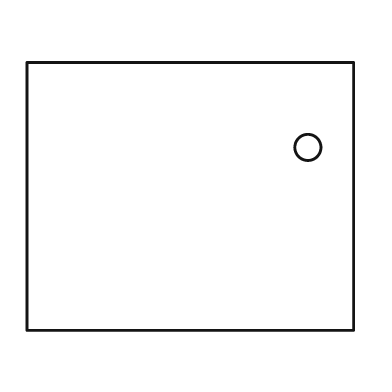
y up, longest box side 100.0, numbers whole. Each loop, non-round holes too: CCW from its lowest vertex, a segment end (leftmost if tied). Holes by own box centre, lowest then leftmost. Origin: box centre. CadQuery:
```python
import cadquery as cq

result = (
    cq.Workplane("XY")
    .moveTo(-50.0, -41.0)
    .lineTo(50.0, -41.0)
    .lineTo(50.0, 41.0)
    .lineTo(-50.0, 41.0)
    .close()
    .moveTo(36.0, 15.0)
    .circle(4.0)
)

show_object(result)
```